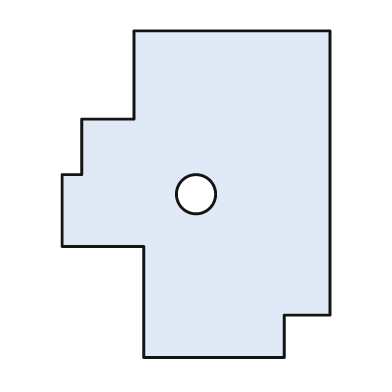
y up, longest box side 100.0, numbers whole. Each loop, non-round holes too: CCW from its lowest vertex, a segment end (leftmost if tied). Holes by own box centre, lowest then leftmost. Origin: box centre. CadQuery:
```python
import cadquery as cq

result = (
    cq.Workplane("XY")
    .moveTo(-16.0, -50.0)
    .lineTo(27.0, -50.0)
    .lineTo(27.0, -37.0)
    .lineTo(41.0, -37.0)
    .lineTo(41.0, 50.0)
    .lineTo(-19.0, 50.0)
    .lineTo(-19.0, 23.0)
    .lineTo(-35.0, 23.0)
    .lineTo(-35.0, 6.0)
    .lineTo(-41.0, 6.0)
    .lineTo(-41.0, -16.0)
    .lineTo(-16.0, -16.0)
    .close()
    .moveTo(0.0, 0.0)
    .circle(6.0)
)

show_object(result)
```